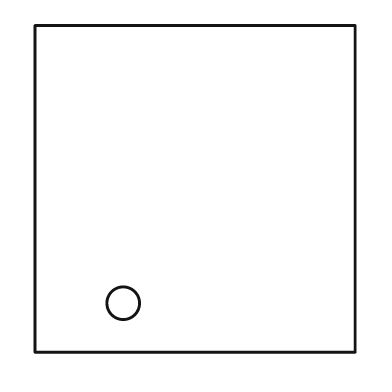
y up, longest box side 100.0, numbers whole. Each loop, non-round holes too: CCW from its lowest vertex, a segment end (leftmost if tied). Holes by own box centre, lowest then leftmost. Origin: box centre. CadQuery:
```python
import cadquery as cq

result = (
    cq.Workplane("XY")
    .moveTo(-49.0, -50.0)
    .lineTo(49.0, -50.0)
    .lineTo(49.0, 50.0)
    .lineTo(-49.0, 50.0)
    .close()
    .moveTo(-22.0, -35.0)
    .circle(5.0)
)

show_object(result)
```